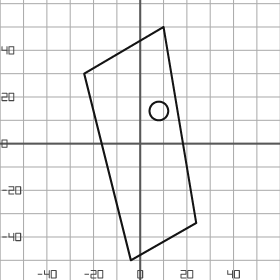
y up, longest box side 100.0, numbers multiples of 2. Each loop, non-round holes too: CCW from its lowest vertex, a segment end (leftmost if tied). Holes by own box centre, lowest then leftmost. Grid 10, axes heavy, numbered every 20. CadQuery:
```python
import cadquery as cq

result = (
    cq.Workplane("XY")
    .moveTo(-4.0, -50.0)
    .lineTo(24.0, -34.0)
    .lineTo(10.0, 50.0)
    .lineTo(-24.0, 30.0)
    .close()
    .moveTo(8.0, 14.0)
    .circle(4.0)
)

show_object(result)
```